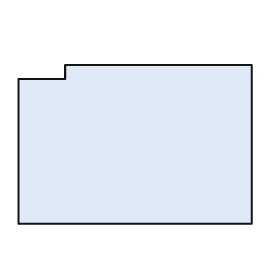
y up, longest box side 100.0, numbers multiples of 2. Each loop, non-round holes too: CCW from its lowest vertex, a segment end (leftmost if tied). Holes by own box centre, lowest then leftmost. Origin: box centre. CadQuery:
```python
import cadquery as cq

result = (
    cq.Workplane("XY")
    .moveTo(-50.0, -34.0)
    .lineTo(50.0, -34.0)
    .lineTo(50.0, 34.0)
    .lineTo(-30.0, 34.0)
    .lineTo(-30.0, 28.0)
    .lineTo(-50.0, 28.0)
    .close()
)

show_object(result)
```